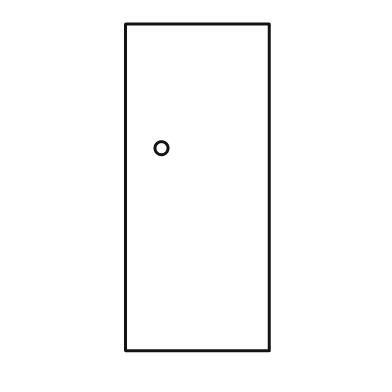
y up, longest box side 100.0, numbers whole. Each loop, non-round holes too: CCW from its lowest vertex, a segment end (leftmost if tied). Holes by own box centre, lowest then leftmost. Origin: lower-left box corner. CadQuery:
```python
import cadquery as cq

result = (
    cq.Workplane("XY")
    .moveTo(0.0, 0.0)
    .lineTo(44.0, 0.0)
    .lineTo(44.0, 100.0)
    .lineTo(0.0, 100.0)
    .close()
    .moveTo(11.0, 62.0)
    .circle(2.0)
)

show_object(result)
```